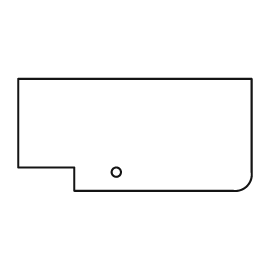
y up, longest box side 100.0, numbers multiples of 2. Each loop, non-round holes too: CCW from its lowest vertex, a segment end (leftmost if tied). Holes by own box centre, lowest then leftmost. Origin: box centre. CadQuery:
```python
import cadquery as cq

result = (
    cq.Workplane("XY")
    .moveTo(-26.0, -24.0)
    .lineTo(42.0, -24.0)
    .threePointArc((48.0, -22.0), (50.0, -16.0))
    .lineTo(50.0, 24.0)
    .lineTo(-50.0, 24.0)
    .lineTo(-50.0, -14.0)
    .lineTo(-26.0, -14.0)
    .close()
    .moveTo(-8.0, -16.0)
    .circle(2.0)
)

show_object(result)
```